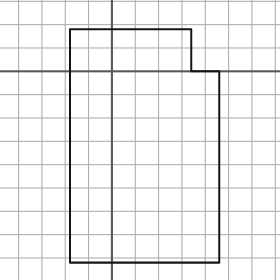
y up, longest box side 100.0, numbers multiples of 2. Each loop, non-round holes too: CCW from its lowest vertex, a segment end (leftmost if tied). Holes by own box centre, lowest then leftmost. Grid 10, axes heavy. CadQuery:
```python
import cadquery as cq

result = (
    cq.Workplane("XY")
    .moveTo(-18.0, -82.0)
    .lineTo(46.0, -82.0)
    .lineTo(46.0, 0.0)
    .lineTo(34.0, 0.0)
    .lineTo(34.0, 18.0)
    .lineTo(-18.0, 18.0)
    .close()
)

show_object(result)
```